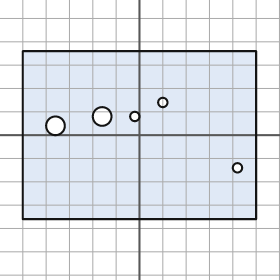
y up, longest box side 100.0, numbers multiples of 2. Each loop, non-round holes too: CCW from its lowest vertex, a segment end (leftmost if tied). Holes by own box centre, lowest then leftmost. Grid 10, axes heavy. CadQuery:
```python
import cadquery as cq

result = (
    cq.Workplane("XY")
    .moveTo(-50.0, -36.0)
    .lineTo(50.0, -36.0)
    .lineTo(50.0, 36.0)
    .lineTo(-50.0, 36.0)
    .close()
    .moveTo(42.0, -14.0)
    .circle(2.0)
    .moveTo(-36.0, 4.0)
    .circle(4.0)
    .moveTo(-16.0, 8.0)
    .circle(4.0)
    .moveTo(-2.0, 8.0)
    .circle(2.0)
    .moveTo(10.0, 14.0)
    .circle(2.0)
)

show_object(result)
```